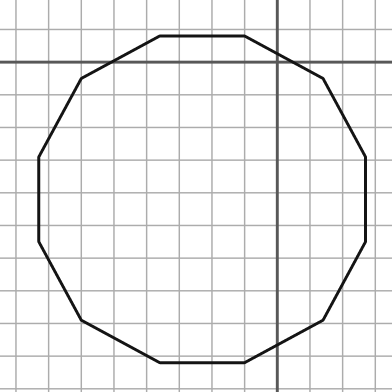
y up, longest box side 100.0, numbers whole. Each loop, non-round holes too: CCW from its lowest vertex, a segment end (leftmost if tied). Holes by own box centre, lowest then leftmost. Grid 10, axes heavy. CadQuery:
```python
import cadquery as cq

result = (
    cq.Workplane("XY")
    .moveTo(-36.0, -92.0)
    .lineTo(-10.0, -92.0)
    .lineTo(14.0, -79.0)
    .lineTo(27.0, -55.0)
    .lineTo(27.0, -29.0)
    .lineTo(14.0, -5.0)
    .lineTo(-10.0, 8.0)
    .lineTo(-36.0, 8.0)
    .lineTo(-60.0, -5.0)
    .lineTo(-73.0, -29.0)
    .lineTo(-73.0, -55.0)
    .lineTo(-60.0, -79.0)
    .close()
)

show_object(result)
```